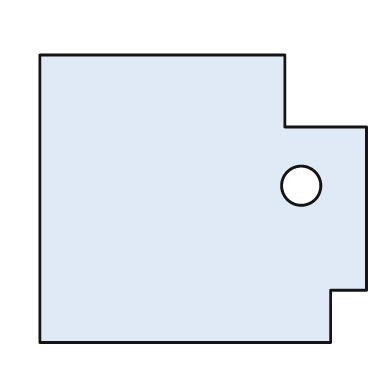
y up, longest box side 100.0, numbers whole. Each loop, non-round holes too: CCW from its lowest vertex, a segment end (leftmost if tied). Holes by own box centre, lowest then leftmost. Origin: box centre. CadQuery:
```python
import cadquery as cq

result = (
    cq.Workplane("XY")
    .moveTo(-50.0, -44.0)
    .lineTo(39.0, -44.0)
    .lineTo(39.0, -28.0)
    .lineTo(50.0, -28.0)
    .lineTo(50.0, 22.0)
    .lineTo(25.0, 22.0)
    .lineTo(25.0, 44.0)
    .lineTo(-50.0, 44.0)
    .close()
    .moveTo(30.0, 4.0)
    .circle(6.0)
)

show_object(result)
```